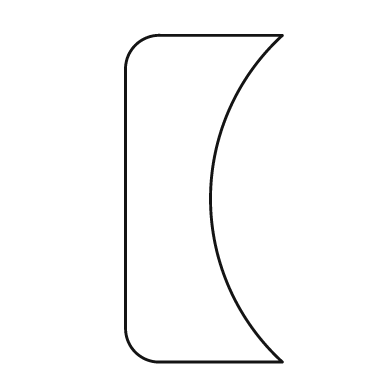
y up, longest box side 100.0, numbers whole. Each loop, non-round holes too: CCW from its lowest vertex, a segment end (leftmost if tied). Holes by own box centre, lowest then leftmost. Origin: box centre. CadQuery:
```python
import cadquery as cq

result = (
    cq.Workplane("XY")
    .moveTo(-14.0, -50.0)
    .lineTo(24.0, -50.0)
    .threePointArc((2.0, 0.0), (24.0, 50.0))
    .lineTo(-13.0, 50.0)
    .threePointArc((-21.0, 47.0), (-24.0, 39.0))
    .lineTo(-24.0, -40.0)
    .threePointArc((-21.0, -47.0), (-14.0, -50.0))
    .close()
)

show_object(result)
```